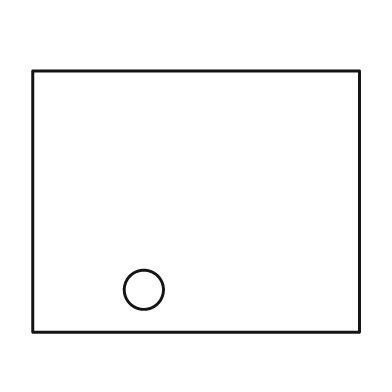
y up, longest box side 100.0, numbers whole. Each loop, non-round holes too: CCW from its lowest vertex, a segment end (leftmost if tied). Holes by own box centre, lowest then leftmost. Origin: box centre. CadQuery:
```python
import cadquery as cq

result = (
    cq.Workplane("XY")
    .moveTo(-50.0, -40.0)
    .lineTo(50.0, -40.0)
    .lineTo(50.0, 40.0)
    .lineTo(-50.0, 40.0)
    .close()
    .moveTo(-16.0, -27.0)
    .circle(6.0)
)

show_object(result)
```